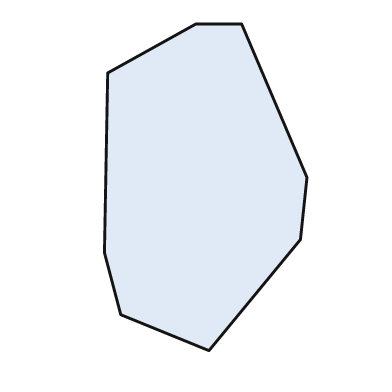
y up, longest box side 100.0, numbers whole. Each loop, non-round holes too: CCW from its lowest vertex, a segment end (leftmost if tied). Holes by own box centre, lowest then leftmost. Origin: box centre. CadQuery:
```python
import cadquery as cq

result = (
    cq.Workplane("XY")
    .moveTo(1.0, -50.0)
    .lineTo(29.0, -16.0)
    .lineTo(31.0, 3.0)
    .lineTo(11.0, 50.0)
    .lineTo(-3.0, 50.0)
    .lineTo(-30.0, 35.0)
    .lineTo(-31.0, -20.0)
    .lineTo(-26.0, -39.0)
    .close()
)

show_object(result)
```